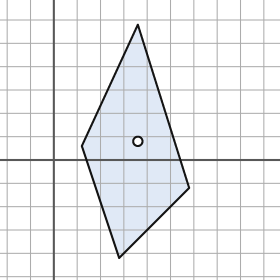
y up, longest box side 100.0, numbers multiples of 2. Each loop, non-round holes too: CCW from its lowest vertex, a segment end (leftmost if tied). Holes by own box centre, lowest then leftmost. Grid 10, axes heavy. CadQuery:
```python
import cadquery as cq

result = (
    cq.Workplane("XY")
    .moveTo(28.0, -42.0)
    .lineTo(58.0, -12.0)
    .lineTo(36.0, 58.0)
    .lineTo(12.0, 6.0)
    .close()
    .moveTo(36.0, 8.0)
    .circle(2.0)
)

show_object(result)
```